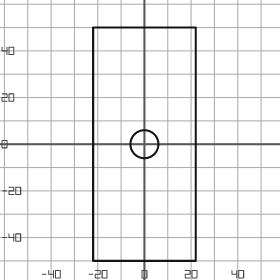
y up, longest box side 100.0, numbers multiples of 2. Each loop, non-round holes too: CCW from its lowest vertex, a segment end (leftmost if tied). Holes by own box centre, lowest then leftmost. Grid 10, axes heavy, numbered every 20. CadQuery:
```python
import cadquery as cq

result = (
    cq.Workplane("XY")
    .moveTo(-22.0, -50.0)
    .lineTo(22.0, -50.0)
    .lineTo(22.0, 50.0)
    .lineTo(-22.0, 50.0)
    .close()
    .moveTo(0.0, 0.0)
    .circle(6.0)
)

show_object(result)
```